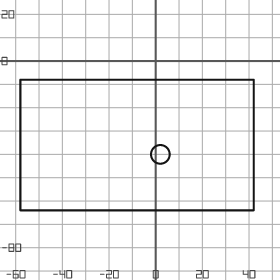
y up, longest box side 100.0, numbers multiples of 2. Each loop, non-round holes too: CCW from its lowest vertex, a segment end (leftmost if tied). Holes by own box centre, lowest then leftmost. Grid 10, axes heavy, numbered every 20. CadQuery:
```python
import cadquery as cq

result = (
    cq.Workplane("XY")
    .moveTo(-58.0, -64.0)
    .lineTo(42.0, -64.0)
    .lineTo(42.0, -8.0)
    .lineTo(-58.0, -8.0)
    .close()
    .moveTo(2.0, -40.0)
    .circle(4.0)
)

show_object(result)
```